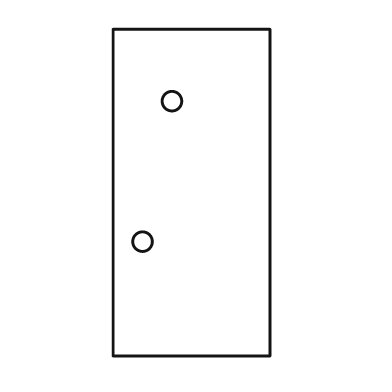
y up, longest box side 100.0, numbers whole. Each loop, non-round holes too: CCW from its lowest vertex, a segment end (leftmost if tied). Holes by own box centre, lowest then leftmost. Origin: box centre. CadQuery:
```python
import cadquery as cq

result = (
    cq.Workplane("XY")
    .moveTo(-24.0, -50.0)
    .lineTo(24.0, -50.0)
    .lineTo(24.0, 50.0)
    .lineTo(-24.0, 50.0)
    .close()
    .moveTo(-15.0, -15.0)
    .circle(3.0)
    .moveTo(-6.0, 28.0)
    .circle(3.0)
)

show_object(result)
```